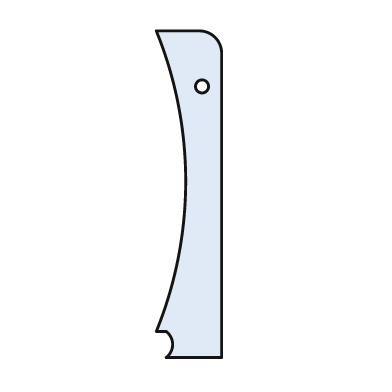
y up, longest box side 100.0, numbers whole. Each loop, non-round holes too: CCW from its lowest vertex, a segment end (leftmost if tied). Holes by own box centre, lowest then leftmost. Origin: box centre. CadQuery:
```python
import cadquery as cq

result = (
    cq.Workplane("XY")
    .moveTo(-7.0, -50.0)
    .lineTo(10.0, -50.0)
    .lineTo(10.0, 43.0)
    .threePointArc((8.0, 48.0), (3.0, 50.0))
    .lineTo(-10.0, 50.0)
    .threePointArc((-1.0, 4.0), (-10.0, -42.0))
    .lineTo(-7.0, -42.0)
    .threePointArc((-5.0, -46.0), (-7.0, -50.0))
    .close()
    .moveTo(4.0, 33.0)
    .circle(2.0)
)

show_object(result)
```